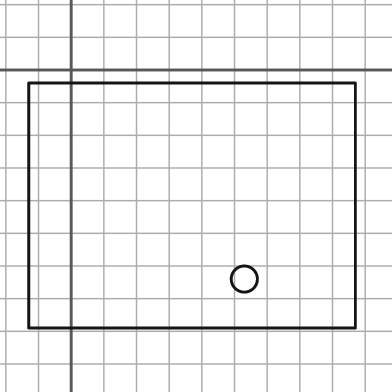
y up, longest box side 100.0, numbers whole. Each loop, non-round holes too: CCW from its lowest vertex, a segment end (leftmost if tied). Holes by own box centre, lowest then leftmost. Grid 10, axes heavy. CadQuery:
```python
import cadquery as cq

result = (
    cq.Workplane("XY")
    .moveTo(-13.0, -79.0)
    .lineTo(87.0, -79.0)
    .lineTo(87.0, -4.0)
    .lineTo(-13.0, -4.0)
    .close()
    .moveTo(53.0, -64.0)
    .circle(4.0)
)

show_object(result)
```